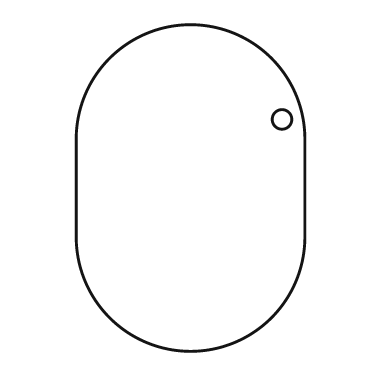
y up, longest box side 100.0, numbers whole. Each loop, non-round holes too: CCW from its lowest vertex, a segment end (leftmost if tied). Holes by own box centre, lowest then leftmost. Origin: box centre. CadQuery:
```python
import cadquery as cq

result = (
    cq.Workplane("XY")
    .moveTo(-35.0, -15.0)
    .threePointArc((0.0, -50.0), (35.0, -15.0))
    .lineTo(35.0, 15.0)
    .threePointArc((0.0, 50.0), (-35.0, 15.0))
    .close()
    .moveTo(28.0, 21.0)
    .circle(3.0)
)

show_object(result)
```